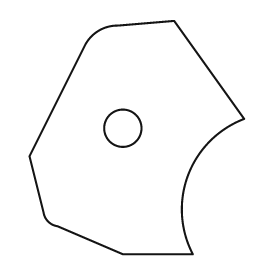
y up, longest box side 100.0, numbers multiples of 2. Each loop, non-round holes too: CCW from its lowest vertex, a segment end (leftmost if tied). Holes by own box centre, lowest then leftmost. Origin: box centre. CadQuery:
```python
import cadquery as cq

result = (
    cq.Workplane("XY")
    .moveTo(-6.0, -50.0)
    .lineTo(24.0, -50.0)
    .threePointArc((22.0, -16.0), (46.0, 8.0))
    .lineTo(16.0, 50.0)
    .lineTo(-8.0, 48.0)
    .threePointArc((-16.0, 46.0), (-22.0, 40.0))
    .lineTo(-46.0, -8.0)
    .lineTo(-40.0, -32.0)
    .threePointArc((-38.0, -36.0), (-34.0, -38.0))
    .close()
    .moveTo(-6.0, 4.0)
    .circle(8.0)
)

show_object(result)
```